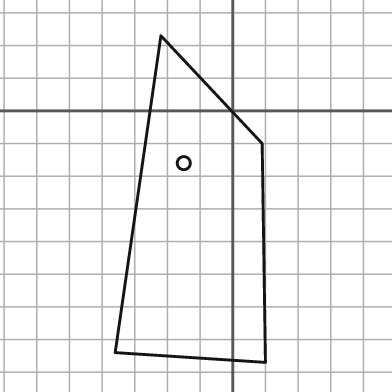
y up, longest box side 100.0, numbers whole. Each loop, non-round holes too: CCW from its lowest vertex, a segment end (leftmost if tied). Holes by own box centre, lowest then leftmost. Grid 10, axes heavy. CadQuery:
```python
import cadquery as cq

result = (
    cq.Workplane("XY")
    .moveTo(10.0, -77.0)
    .lineTo(9.0, -10.0)
    .lineTo(-22.0, 23.0)
    .lineTo(-36.0, -74.0)
    .close()
    .moveTo(-15.0, -16.0)
    .circle(2.0)
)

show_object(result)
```